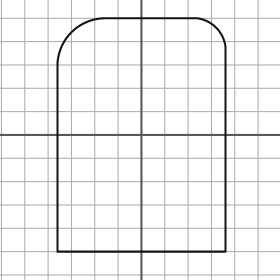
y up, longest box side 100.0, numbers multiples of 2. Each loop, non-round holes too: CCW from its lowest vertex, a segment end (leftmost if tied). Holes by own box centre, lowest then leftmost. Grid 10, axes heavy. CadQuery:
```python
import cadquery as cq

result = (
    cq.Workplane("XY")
    .moveTo(-36.0, -50.0)
    .lineTo(36.0, -50.0)
    .lineTo(36.0, 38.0)
    .threePointArc((32.0, 46.0), (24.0, 50.0))
    .lineTo(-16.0, 50.0)
    .threePointArc((-30.0, 44.0), (-36.0, 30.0))
    .close()
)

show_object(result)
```